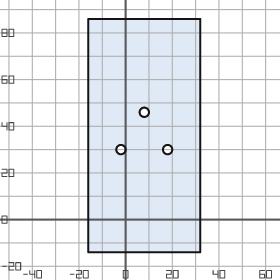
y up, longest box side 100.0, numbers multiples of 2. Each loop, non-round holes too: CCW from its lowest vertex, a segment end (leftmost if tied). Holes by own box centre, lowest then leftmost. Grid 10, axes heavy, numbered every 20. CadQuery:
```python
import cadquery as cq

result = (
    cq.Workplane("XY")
    .moveTo(-16.0, -14.0)
    .lineTo(32.0, -14.0)
    .lineTo(32.0, 86.0)
    .lineTo(-16.0, 86.0)
    .close()
    .moveTo(-2.0, 30.0)
    .circle(2.0)
    .moveTo(18.0, 30.0)
    .circle(2.0)
    .moveTo(8.0, 46.0)
    .circle(2.0)
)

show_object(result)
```